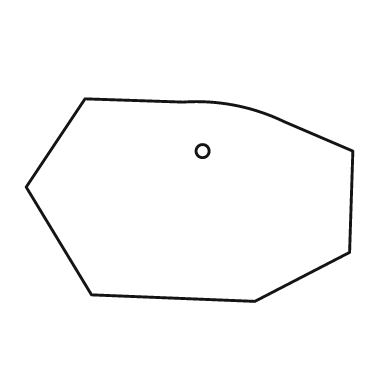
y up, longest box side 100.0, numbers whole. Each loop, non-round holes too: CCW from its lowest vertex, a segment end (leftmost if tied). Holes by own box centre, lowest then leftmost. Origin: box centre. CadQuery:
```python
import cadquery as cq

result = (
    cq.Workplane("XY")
    .moveTo(20.0, -31.0)
    .lineTo(49.0, -16.0)
    .lineTo(50.0, 15.0)
    .lineTo(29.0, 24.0)
    .threePointArc((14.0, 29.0), (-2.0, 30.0))
    .lineTo(-32.0, 31.0)
    .lineTo(-50.0, 4.0)
    .lineTo(-30.0, -29.0)
    .close()
    .moveTo(4.0, 15.0)
    .circle(2.0)
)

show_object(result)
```